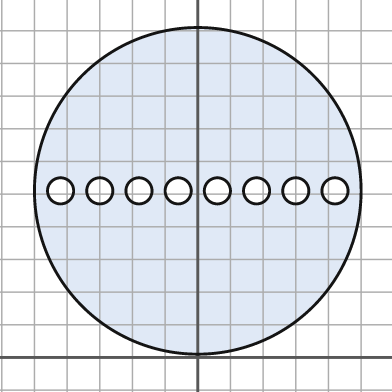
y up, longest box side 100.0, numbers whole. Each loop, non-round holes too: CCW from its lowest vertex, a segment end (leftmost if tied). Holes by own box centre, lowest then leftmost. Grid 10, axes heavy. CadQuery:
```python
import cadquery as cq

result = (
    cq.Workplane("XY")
    .moveTo(0.0, 51.0)
    .circle(50.0)
    .moveTo(-42.0, 51.0)
    .circle(4.0)
    .moveTo(-30.0, 51.0)
    .circle(4.0)
    .moveTo(-18.0, 51.0)
    .circle(4.0)
    .moveTo(-6.0, 51.0)
    .circle(4.0)
    .moveTo(6.0, 51.0)
    .circle(4.0)
    .moveTo(18.0, 51.0)
    .circle(4.0)
    .moveTo(30.0, 51.0)
    .circle(4.0)
    .moveTo(42.0, 51.0)
    .circle(4.0)
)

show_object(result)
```